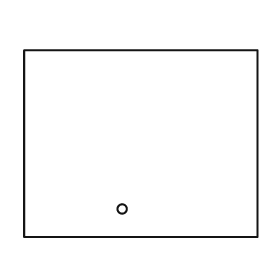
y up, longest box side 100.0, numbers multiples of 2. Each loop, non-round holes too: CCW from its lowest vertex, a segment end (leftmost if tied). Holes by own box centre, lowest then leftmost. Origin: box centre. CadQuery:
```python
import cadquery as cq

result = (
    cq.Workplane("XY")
    .moveTo(-50.0, -40.0)
    .lineTo(50.0, -40.0)
    .lineTo(50.0, 40.0)
    .lineTo(-50.0, 40.0)
    .close()
    .moveTo(-8.0, -28.0)
    .circle(2.0)
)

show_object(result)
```